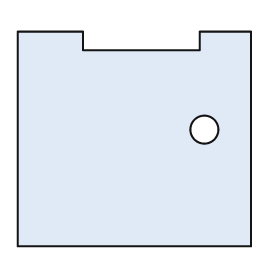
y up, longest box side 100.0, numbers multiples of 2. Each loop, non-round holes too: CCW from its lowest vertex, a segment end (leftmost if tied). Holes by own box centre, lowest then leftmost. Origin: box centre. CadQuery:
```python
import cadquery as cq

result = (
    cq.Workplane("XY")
    .moveTo(-50.0, -46.0)
    .lineTo(50.0, -46.0)
    .lineTo(50.0, 46.0)
    .lineTo(28.0, 46.0)
    .lineTo(28.0, 38.0)
    .lineTo(-22.0, 38.0)
    .lineTo(-22.0, 46.0)
    .lineTo(-50.0, 46.0)
    .close()
    .moveTo(30.0, 4.0)
    .circle(6.0)
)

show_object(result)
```